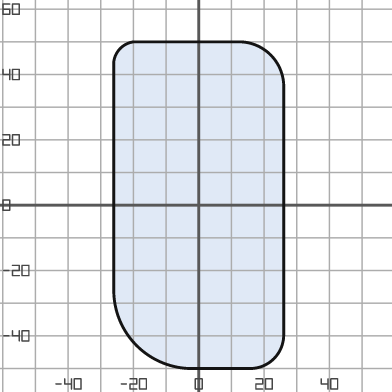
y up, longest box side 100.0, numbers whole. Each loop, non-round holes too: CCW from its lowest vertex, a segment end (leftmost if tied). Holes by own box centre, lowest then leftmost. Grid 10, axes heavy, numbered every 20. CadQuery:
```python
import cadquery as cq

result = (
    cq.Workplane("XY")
    .moveTo(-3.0, -50.0)
    .lineTo(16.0, -50.0)
    .threePointArc((23.0, -47.0), (26.0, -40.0))
    .lineTo(26.0, 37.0)
    .threePointArc((22.0, 46.0), (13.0, 50.0))
    .lineTo(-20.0, 50.0)
    .threePointArc((-24.0, 48.0), (-26.0, 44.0))
    .lineTo(-26.0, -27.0)
    .threePointArc((-19.0, -43.0), (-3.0, -50.0))
    .close()
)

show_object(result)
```